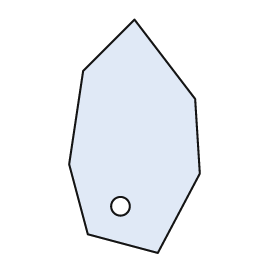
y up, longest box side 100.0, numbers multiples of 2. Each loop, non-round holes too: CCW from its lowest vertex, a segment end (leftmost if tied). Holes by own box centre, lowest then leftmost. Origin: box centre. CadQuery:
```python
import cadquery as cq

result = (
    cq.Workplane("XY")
    .moveTo(10.0, -50.0)
    .lineTo(28.0, -16.0)
    .lineTo(26.0, 16.0)
    .lineTo(0.0, 50.0)
    .lineTo(-22.0, 28.0)
    .lineTo(-28.0, -12.0)
    .lineTo(-20.0, -42.0)
    .close()
    .moveTo(-6.0, -30.0)
    .circle(4.0)
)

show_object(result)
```